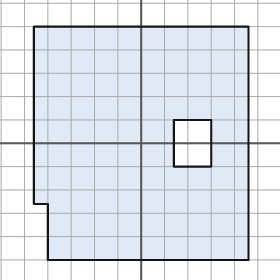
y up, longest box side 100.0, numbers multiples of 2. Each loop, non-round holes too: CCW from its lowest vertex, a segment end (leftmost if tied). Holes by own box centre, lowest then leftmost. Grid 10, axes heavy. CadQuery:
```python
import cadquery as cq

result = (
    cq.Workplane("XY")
    .moveTo(-40.0, -50.0)
    .lineTo(46.0, -50.0)
    .lineTo(46.0, 50.0)
    .lineTo(-46.0, 50.0)
    .lineTo(-46.0, -26.0)
    .lineTo(-40.0, -26.0)
    .close()
    .moveTo(14.0, -10.0)
    .lineTo(30.0, -10.0)
    .lineTo(30.0, 10.0)
    .lineTo(14.0, 10.0)
    .close()
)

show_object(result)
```